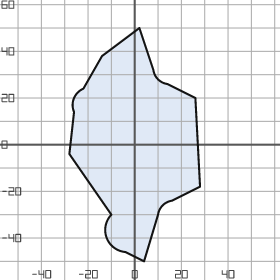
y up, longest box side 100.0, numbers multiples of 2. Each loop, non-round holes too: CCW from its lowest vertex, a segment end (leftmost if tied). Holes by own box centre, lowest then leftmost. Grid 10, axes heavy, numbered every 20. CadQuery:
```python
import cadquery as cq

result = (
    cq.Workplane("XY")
    .moveTo(4.0, -50.0)
    .lineTo(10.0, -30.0)
    .threePointArc((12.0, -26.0), (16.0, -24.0))
    .lineTo(28.0, -18.0)
    .lineTo(26.0, 20.0)
    .lineTo(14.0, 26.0)
    .threePointArc((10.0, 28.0), (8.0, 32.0))
    .lineTo(2.0, 50.0)
    .lineTo(-14.0, 38.0)
    .lineTo(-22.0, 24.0)
    .threePointArc((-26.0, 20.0), (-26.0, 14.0))
    .lineTo(-28.0, -4.0)
    .lineTo(-10.0, -30.0)
    .threePointArc((-12.0, -40.0), (-4.0, -46.0))
    .close()
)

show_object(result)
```